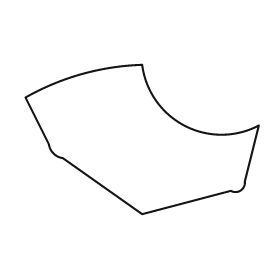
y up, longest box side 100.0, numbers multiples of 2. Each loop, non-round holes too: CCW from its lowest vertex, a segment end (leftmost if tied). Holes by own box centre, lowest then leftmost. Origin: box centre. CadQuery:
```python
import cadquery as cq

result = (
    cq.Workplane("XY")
    .moveTo(0.0, -32.0)
    .lineTo(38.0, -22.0)
    .threePointArc((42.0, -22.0), (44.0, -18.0))
    .lineTo(50.0, 6.0)
    .threePointArc((18.0, 6.0), (0.0, 32.0))
    .threePointArc((-26.0, 28.0), (-50.0, 18.0))
    .lineTo(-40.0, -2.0)
    .threePointArc((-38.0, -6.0), (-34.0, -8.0))
    .close()
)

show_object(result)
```